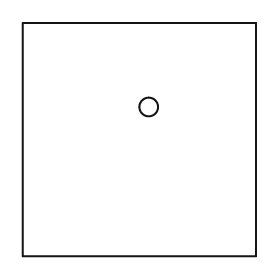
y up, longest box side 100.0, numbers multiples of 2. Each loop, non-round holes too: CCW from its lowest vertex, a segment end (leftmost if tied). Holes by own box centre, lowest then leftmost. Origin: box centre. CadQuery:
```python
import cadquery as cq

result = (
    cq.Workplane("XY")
    .moveTo(-50.0, -50.0)
    .lineTo(50.0, -50.0)
    .lineTo(50.0, 50.0)
    .lineTo(-50.0, 50.0)
    .close()
    .moveTo(4.0, 14.0)
    .circle(4.0)
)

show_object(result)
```